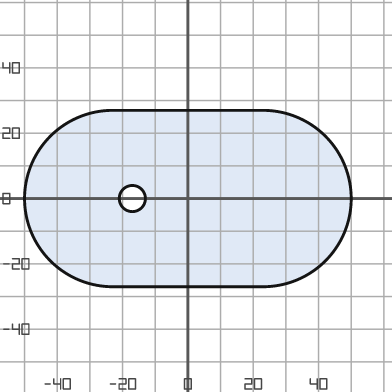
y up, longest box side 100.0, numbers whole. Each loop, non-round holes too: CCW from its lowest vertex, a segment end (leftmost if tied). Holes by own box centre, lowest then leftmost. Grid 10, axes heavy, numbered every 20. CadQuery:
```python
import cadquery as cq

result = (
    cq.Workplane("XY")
    .moveTo(-23.0, -27.0)
    .lineTo(23.0, -27.0)
    .threePointArc((50.0, 0.0), (23.0, 27.0))
    .lineTo(-23.0, 27.0)
    .threePointArc((-50.0, 0.0), (-23.0, -27.0))
    .close()
    .moveTo(-17.0, 0.0)
    .circle(4.0)
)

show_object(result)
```